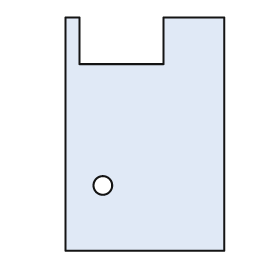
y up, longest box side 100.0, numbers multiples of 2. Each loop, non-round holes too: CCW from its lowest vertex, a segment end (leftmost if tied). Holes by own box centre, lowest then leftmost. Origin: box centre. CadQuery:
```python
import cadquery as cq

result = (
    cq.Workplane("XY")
    .moveTo(-34.0, -50.0)
    .lineTo(34.0, -50.0)
    .lineTo(34.0, 50.0)
    .lineTo(8.0, 50.0)
    .lineTo(8.0, 30.0)
    .lineTo(-28.0, 30.0)
    .lineTo(-28.0, 50.0)
    .lineTo(-34.0, 50.0)
    .close()
    .moveTo(-18.0, -22.0)
    .circle(4.0)
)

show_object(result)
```